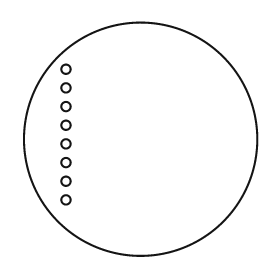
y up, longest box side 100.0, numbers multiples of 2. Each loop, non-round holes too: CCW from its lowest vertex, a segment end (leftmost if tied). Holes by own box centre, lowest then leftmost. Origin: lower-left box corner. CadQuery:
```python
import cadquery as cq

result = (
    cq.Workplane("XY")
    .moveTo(50.0, 50.0)
    .circle(50.0)
    .moveTo(18.0, 24.0)
    .circle(2.0)
    .moveTo(18.0, 32.0)
    .circle(2.0)
    .moveTo(18.0, 40.0)
    .circle(2.0)
    .moveTo(18.0, 48.0)
    .circle(2.0)
    .moveTo(18.0, 56.0)
    .circle(2.0)
    .moveTo(18.0, 64.0)
    .circle(2.0)
    .moveTo(18.0, 72.0)
    .circle(2.0)
    .moveTo(18.0, 80.0)
    .circle(2.0)
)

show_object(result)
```